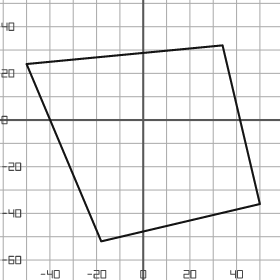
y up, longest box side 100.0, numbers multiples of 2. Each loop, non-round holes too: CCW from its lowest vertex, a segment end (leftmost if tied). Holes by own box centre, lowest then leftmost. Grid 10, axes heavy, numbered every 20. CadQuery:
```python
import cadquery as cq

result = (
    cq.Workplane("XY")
    .moveTo(-18.0, -52.0)
    .lineTo(50.0, -36.0)
    .lineTo(34.0, 32.0)
    .lineTo(-50.0, 24.0)
    .close()
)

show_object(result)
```